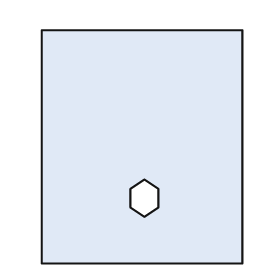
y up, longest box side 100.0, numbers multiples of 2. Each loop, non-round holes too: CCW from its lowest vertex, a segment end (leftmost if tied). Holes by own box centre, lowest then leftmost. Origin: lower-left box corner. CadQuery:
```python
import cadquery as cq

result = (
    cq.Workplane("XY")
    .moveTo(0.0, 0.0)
    .lineTo(86.0, 0.0)
    .lineTo(86.0, 100.0)
    .lineTo(0.0, 100.0)
    .close()
    .moveTo(44.0, 20.0)
    .lineTo(50.0, 24.0)
    .lineTo(50.0, 32.0)
    .lineTo(44.0, 36.0)
    .lineTo(38.0, 32.0)
    .lineTo(38.0, 24.0)
    .close()
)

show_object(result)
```